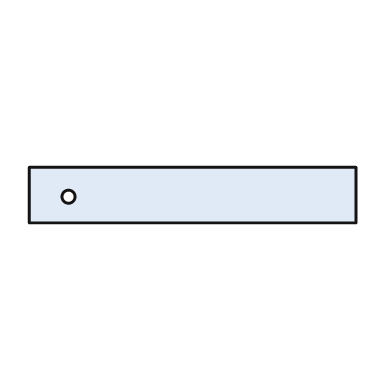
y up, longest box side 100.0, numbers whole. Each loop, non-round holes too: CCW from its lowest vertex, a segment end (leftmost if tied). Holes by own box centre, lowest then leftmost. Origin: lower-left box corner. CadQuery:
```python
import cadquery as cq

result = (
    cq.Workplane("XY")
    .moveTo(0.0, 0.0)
    .lineTo(100.0, 0.0)
    .lineTo(100.0, 17.0)
    .lineTo(0.0, 17.0)
    .close()
    .moveTo(12.0, 8.0)
    .circle(2.0)
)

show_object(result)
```